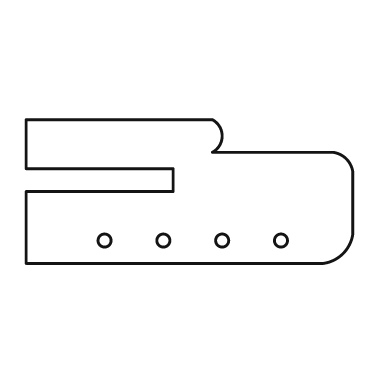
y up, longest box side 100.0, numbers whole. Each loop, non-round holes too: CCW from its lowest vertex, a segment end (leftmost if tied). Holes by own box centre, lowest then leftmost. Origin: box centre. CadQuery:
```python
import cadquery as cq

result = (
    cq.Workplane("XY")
    .moveTo(-50.0, -22.0)
    .lineTo(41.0, -22.0)
    .threePointArc((47.0, -19.0), (50.0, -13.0))
    .lineTo(50.0, 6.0)
    .threePointArc((48.0, 10.0), (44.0, 12.0))
    .lineTo(7.0, 12.0)
    .threePointArc((10.0, 17.0), (7.0, 22.0))
    .lineTo(-50.0, 22.0)
    .lineTo(-50.0, 7.0)
    .lineTo(-5.0, 7.0)
    .lineTo(-5.0, 0.0)
    .lineTo(-50.0, 0.0)
    .close()
    .moveTo(-26.0, -15.0)
    .circle(2.0)
    .moveTo(-8.0, -15.0)
    .circle(2.0)
    .moveTo(10.0, -15.0)
    .circle(2.0)
    .moveTo(28.0, -15.0)
    .circle(2.0)
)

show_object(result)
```